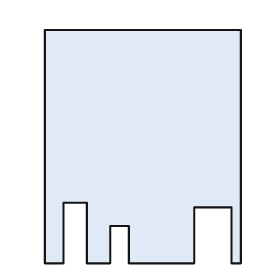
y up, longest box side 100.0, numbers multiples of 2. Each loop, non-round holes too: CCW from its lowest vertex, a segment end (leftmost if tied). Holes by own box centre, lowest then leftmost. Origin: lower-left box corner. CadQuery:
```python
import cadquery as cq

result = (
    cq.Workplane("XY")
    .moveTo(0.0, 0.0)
    .lineTo(8.0, 0.0)
    .lineTo(8.0, 26.0)
    .lineTo(18.0, 26.0)
    .lineTo(18.0, 0.0)
    .lineTo(28.0, 0.0)
    .lineTo(28.0, 16.0)
    .lineTo(36.0, 16.0)
    .lineTo(36.0, 0.0)
    .lineTo(64.0, 0.0)
    .lineTo(64.0, 24.0)
    .lineTo(80.0, 24.0)
    .lineTo(80.0, 0.0)
    .lineTo(84.0, 0.0)
    .lineTo(84.0, 100.0)
    .lineTo(0.0, 100.0)
    .close()
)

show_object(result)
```